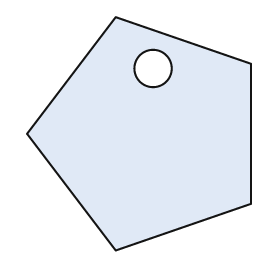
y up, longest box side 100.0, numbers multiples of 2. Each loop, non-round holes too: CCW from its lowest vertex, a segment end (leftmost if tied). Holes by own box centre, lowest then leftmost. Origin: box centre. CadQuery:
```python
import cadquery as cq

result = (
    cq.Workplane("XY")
    .moveTo(-10.0, -50.0)
    .lineTo(48.0, -30.0)
    .lineTo(48.0, 30.0)
    .lineTo(-10.0, 50.0)
    .lineTo(-48.0, 0.0)
    .close()
    .moveTo(6.0, 28.0)
    .circle(8.0)
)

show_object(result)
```